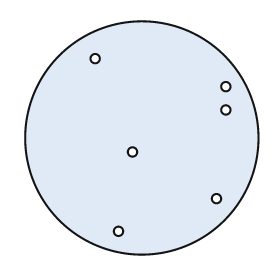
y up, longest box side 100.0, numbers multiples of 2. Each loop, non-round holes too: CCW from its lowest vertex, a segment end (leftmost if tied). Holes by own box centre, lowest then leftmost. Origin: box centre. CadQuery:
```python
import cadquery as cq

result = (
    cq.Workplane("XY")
    .moveTo(0.0, 0.0)
    .circle(50.0)
    .moveTo(-10.0, -40.0)
    .circle(2.0)
    .moveTo(32.0, -26.0)
    .circle(2.0)
    .moveTo(-4.0, -6.0)
    .circle(2.0)
    .moveTo(36.0, 12.0)
    .circle(2.0)
    .moveTo(36.0, 22.0)
    .circle(2.0)
    .moveTo(-20.0, 34.0)
    .circle(2.0)
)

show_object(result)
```